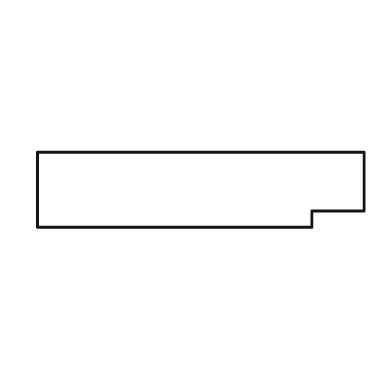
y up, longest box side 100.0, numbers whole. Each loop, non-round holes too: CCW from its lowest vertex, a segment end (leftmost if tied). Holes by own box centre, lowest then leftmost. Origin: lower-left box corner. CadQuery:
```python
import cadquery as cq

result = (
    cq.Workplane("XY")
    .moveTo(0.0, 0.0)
    .lineTo(84.0, 0.0)
    .lineTo(84.0, 5.0)
    .lineTo(100.0, 5.0)
    .lineTo(100.0, 23.0)
    .lineTo(0.0, 23.0)
    .close()
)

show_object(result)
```